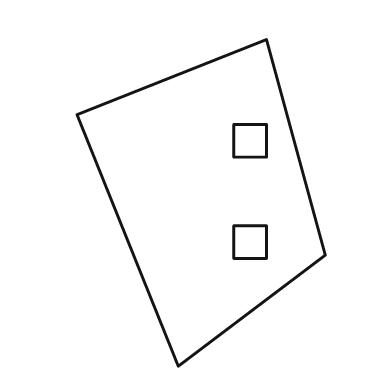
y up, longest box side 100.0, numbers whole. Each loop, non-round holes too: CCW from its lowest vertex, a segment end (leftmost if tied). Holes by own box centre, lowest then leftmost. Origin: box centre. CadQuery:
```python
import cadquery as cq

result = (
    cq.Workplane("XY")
    .moveTo(-7.0, -50.0)
    .lineTo(38.0, -16.0)
    .lineTo(20.0, 50.0)
    .lineTo(-38.0, 27.0)
    .close()
    .moveTo(10.0, -17.0)
    .lineTo(20.0, -17.0)
    .lineTo(20.0, -7.0)
    .lineTo(10.0, -7.0)
    .close()
    .moveTo(10.0, 14.0)
    .lineTo(20.0, 14.0)
    .lineTo(20.0, 24.0)
    .lineTo(10.0, 24.0)
    .close()
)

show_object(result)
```